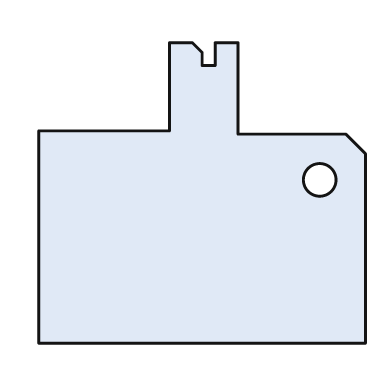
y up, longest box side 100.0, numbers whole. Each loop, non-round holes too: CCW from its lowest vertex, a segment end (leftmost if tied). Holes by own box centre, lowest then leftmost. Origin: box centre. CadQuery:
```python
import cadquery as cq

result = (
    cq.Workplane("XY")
    .moveTo(-50.0, -46.0)
    .lineTo(50.0, -46.0)
    .lineTo(50.0, 12.0)
    .lineTo(44.0, 18.0)
    .lineTo(11.0, 18.0)
    .lineTo(11.0, 46.0)
    .lineTo(4.0, 46.0)
    .lineTo(4.0, 39.0)
    .lineTo(0.0, 39.0)
    .lineTo(0.0, 43.0)
    .lineTo(-3.0, 46.0)
    .lineTo(-10.0, 46.0)
    .lineTo(-10.0, 19.0)
    .lineTo(-50.0, 19.0)
    .close()
    .moveTo(36.0, 4.0)
    .circle(5.0)
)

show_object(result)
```